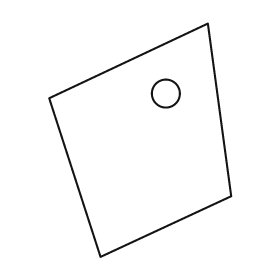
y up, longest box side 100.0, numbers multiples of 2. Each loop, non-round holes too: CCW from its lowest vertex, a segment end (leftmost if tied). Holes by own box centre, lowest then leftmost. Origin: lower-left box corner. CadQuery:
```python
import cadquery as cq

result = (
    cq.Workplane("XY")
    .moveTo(22.0, 0.0)
    .lineTo(78.0, 26.0)
    .lineTo(68.0, 100.0)
    .lineTo(0.0, 68.0)
    .close()
    .moveTo(50.0, 70.0)
    .circle(6.0)
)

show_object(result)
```